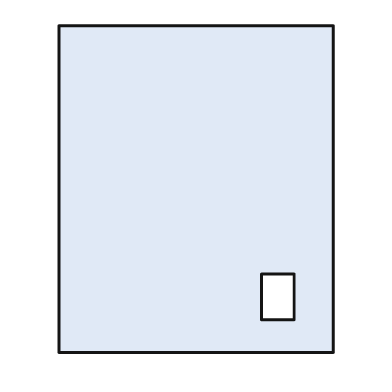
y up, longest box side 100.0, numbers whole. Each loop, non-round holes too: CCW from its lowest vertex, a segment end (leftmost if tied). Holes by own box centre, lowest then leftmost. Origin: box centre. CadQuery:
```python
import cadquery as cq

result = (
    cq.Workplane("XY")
    .moveTo(-42.0, -50.0)
    .lineTo(42.0, -50.0)
    .lineTo(42.0, 50.0)
    .lineTo(-42.0, 50.0)
    .close()
    .moveTo(20.0, -40.0)
    .lineTo(30.0, -40.0)
    .lineTo(30.0, -26.0)
    .lineTo(20.0, -26.0)
    .close()
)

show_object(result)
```